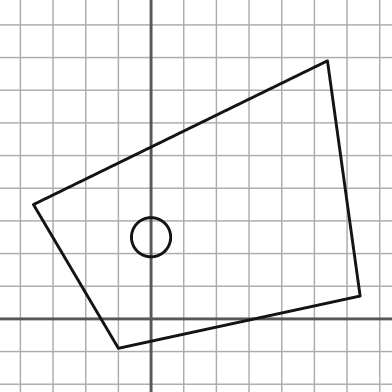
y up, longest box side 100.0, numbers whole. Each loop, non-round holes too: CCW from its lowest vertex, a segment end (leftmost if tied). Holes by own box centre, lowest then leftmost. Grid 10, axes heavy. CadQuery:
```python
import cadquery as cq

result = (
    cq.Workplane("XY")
    .moveTo(-10.0, -9.0)
    .lineTo(64.0, 7.0)
    .lineTo(54.0, 79.0)
    .lineTo(-36.0, 35.0)
    .close()
    .moveTo(0.0, 25.0)
    .circle(6.0)
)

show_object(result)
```